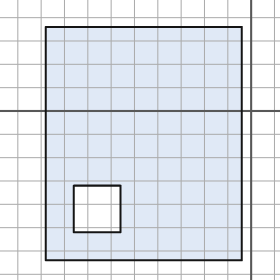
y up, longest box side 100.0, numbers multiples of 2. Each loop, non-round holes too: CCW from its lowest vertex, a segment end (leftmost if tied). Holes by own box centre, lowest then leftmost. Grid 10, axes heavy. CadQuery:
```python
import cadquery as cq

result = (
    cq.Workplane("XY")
    .moveTo(-88.0, -64.0)
    .lineTo(-4.0, -64.0)
    .lineTo(-4.0, 36.0)
    .lineTo(-88.0, 36.0)
    .close()
    .moveTo(-76.0, -52.0)
    .lineTo(-56.0, -52.0)
    .lineTo(-56.0, -32.0)
    .lineTo(-76.0, -32.0)
    .close()
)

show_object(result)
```